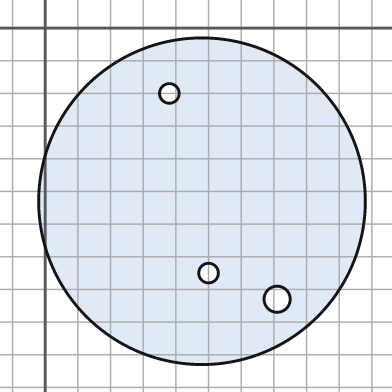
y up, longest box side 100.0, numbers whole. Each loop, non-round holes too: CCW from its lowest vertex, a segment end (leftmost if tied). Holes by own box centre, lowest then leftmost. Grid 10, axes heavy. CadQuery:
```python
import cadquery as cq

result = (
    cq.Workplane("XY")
    .moveTo(48.0, -53.0)
    .circle(50.0)
    .moveTo(71.0, -83.0)
    .circle(4.0)
    .moveTo(50.0, -75.0)
    .circle(3.0)
    .moveTo(38.0, -20.0)
    .circle(3.0)
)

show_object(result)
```